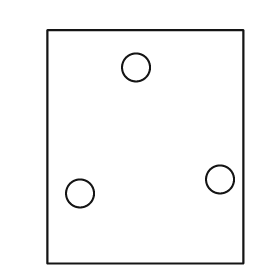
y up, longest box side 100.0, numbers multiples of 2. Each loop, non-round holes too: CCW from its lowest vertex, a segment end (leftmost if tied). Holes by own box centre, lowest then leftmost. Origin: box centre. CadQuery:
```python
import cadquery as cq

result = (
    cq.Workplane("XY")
    .moveTo(-42.0, -50.0)
    .lineTo(42.0, -50.0)
    .lineTo(42.0, 50.0)
    .lineTo(-42.0, 50.0)
    .close()
    .moveTo(-28.0, -20.0)
    .circle(6.0)
    .moveTo(32.0, -14.0)
    .circle(6.0)
    .moveTo(-4.0, 34.0)
    .circle(6.0)
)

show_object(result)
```